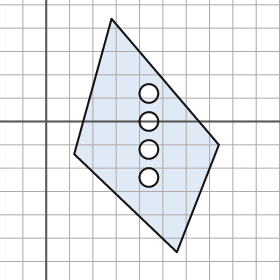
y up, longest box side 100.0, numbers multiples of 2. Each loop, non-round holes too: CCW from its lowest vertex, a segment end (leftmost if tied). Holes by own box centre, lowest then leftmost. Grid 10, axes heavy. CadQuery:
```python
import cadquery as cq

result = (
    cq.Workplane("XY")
    .moveTo(56.0, -56.0)
    .lineTo(74.0, -10.0)
    .lineTo(28.0, 44.0)
    .lineTo(12.0, -14.0)
    .close()
    .moveTo(44.0, -24.0)
    .circle(4.0)
    .moveTo(44.0, -12.0)
    .circle(4.0)
    .moveTo(44.0, 0.0)
    .circle(4.0)
    .moveTo(44.0, 12.0)
    .circle(4.0)
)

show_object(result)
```